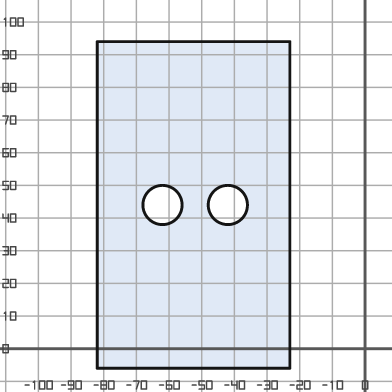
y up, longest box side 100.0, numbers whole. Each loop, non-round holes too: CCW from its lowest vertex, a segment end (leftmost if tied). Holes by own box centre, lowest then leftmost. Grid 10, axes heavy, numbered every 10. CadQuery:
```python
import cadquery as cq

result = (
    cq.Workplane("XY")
    .moveTo(-82.0, -6.0)
    .lineTo(-23.0, -6.0)
    .lineTo(-23.0, 94.0)
    .lineTo(-82.0, 94.0)
    .close()
    .moveTo(-62.0, 44.0)
    .circle(6.0)
    .moveTo(-42.0, 44.0)
    .circle(6.0)
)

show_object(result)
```